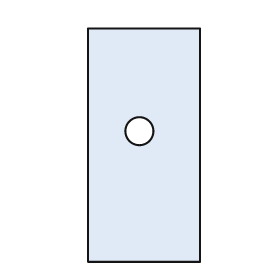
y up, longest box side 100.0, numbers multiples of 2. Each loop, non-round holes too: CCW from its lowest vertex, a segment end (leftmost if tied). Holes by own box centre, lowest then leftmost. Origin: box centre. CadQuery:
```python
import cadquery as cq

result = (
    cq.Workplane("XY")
    .moveTo(-24.0, -50.0)
    .lineTo(24.0, -50.0)
    .lineTo(24.0, 50.0)
    .lineTo(-24.0, 50.0)
    .close()
    .moveTo(-2.0, 6.0)
    .circle(6.0)
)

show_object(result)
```